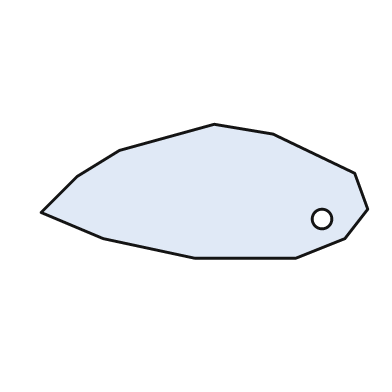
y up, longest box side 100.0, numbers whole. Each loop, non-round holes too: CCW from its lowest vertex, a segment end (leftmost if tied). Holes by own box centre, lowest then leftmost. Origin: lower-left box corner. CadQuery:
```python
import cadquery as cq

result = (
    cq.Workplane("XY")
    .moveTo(47.0, 0.0)
    .lineTo(78.0, 0.0)
    .lineTo(93.0, 6.0)
    .lineTo(100.0, 15.0)
    .lineTo(96.0, 26.0)
    .lineTo(71.0, 38.0)
    .lineTo(53.0, 41.0)
    .lineTo(24.0, 33.0)
    .lineTo(11.0, 25.0)
    .lineTo(0.0, 14.0)
    .lineTo(19.0, 6.0)
    .close()
    .moveTo(86.0, 12.0)
    .circle(3.0)
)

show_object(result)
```